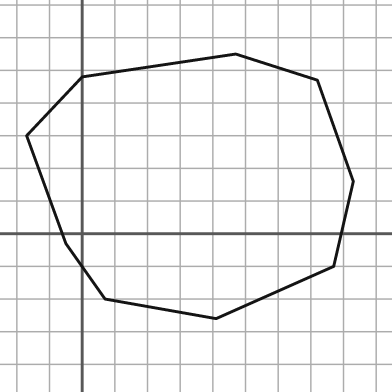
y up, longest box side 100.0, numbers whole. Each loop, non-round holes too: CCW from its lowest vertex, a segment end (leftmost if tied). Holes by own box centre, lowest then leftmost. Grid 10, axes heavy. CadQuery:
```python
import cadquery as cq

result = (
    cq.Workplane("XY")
    .moveTo(41.0, -26.0)
    .lineTo(77.0, -10.0)
    .lineTo(83.0, 16.0)
    .lineTo(72.0, 47.0)
    .lineTo(47.0, 55.0)
    .lineTo(0.0, 48.0)
    .lineTo(-17.0, 30.0)
    .lineTo(-5.0, -3.0)
    .lineTo(7.0, -20.0)
    .close()
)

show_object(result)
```